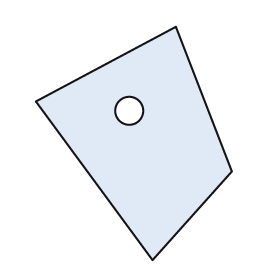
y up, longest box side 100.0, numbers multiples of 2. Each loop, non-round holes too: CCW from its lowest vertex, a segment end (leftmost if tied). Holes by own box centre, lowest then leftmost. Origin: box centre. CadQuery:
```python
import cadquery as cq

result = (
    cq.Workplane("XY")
    .moveTo(8.0, -50.0)
    .lineTo(42.0, -12.0)
    .lineTo(18.0, 50.0)
    .lineTo(-42.0, 18.0)
    .close()
    .moveTo(-2.0, 14.0)
    .circle(6.0)
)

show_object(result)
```